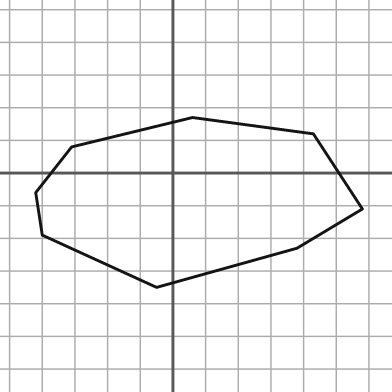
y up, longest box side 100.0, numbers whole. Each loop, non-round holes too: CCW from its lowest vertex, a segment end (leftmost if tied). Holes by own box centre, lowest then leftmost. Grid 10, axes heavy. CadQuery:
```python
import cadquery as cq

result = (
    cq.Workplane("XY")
    .moveTo(-5.0, -35.0)
    .lineTo(38.0, -23.0)
    .lineTo(58.0, -11.0)
    .lineTo(43.0, 12.0)
    .lineTo(6.0, 17.0)
    .lineTo(-31.0, 8.0)
    .lineTo(-42.0, -6.0)
    .lineTo(-40.0, -19.0)
    .close()
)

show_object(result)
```